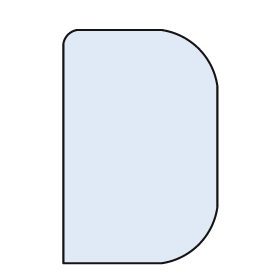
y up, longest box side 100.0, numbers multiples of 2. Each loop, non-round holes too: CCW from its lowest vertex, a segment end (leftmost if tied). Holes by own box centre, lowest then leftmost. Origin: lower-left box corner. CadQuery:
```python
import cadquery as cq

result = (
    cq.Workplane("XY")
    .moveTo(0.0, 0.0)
    .lineTo(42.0, 0.0)
    .threePointArc((58.0, 8.0), (66.0, 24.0))
    .lineTo(66.0, 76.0)
    .threePointArc((58.0, 92.0), (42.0, 100.0))
    .lineTo(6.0, 100.0)
    .threePointArc((2.0, 98.0), (0.0, 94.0))
    .close()
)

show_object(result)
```